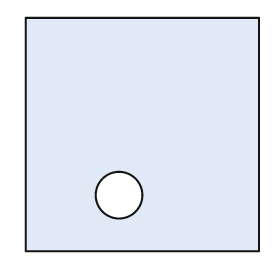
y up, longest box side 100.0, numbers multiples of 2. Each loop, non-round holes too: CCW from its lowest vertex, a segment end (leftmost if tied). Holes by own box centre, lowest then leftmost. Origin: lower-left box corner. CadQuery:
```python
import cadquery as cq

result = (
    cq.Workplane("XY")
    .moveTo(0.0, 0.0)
    .lineTo(100.0, 0.0)
    .lineTo(100.0, 100.0)
    .lineTo(0.0, 100.0)
    .close()
    .moveTo(40.0, 24.0)
    .circle(10.0)
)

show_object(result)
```